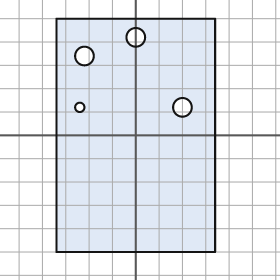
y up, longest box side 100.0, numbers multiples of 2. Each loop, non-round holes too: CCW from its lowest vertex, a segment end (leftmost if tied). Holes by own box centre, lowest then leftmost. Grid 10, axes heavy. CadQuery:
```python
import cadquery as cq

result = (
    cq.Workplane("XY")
    .moveTo(-34.0, -50.0)
    .lineTo(34.0, -50.0)
    .lineTo(34.0, 50.0)
    .lineTo(-34.0, 50.0)
    .close()
    .moveTo(-24.0, 12.0)
    .circle(2.0)
    .moveTo(20.0, 12.0)
    .circle(4.0)
    .moveTo(-22.0, 34.0)
    .circle(4.0)
    .moveTo(0.0, 42.0)
    .circle(4.0)
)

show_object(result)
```